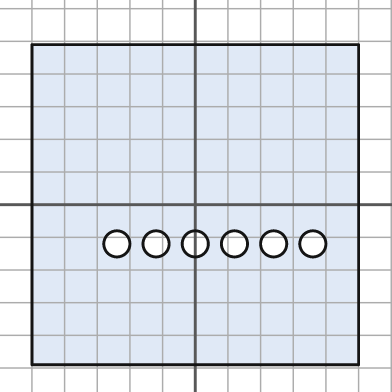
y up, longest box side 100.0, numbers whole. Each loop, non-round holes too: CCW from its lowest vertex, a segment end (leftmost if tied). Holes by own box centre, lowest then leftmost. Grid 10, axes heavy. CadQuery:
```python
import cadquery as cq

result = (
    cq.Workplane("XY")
    .moveTo(-50.0, -49.0)
    .lineTo(50.0, -49.0)
    .lineTo(50.0, 49.0)
    .lineTo(-50.0, 49.0)
    .close()
    .moveTo(-24.0, -12.0)
    .circle(4.0)
    .moveTo(-12.0, -12.0)
    .circle(4.0)
    .moveTo(0.0, -12.0)
    .circle(4.0)
    .moveTo(12.0, -12.0)
    .circle(4.0)
    .moveTo(24.0, -12.0)
    .circle(4.0)
    .moveTo(36.0, -12.0)
    .circle(4.0)
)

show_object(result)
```